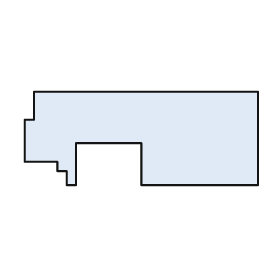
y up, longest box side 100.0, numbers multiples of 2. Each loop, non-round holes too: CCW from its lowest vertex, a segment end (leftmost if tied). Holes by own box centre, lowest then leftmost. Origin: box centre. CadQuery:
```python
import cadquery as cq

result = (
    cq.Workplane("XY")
    .moveTo(-32.0, -20.0)
    .lineTo(-28.0, -20.0)
    .lineTo(-28.0, -2.0)
    .lineTo(0.0, -2.0)
    .lineTo(0.0, -20.0)
    .lineTo(50.0, -20.0)
    .lineTo(50.0, 20.0)
    .lineTo(-46.0, 20.0)
    .lineTo(-46.0, 8.0)
    .lineTo(-50.0, 8.0)
    .lineTo(-50.0, -10.0)
    .lineTo(-36.0, -10.0)
    .lineTo(-36.0, -14.0)
    .lineTo(-32.0, -14.0)
    .close()
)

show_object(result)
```